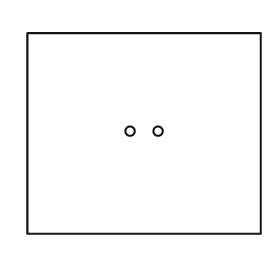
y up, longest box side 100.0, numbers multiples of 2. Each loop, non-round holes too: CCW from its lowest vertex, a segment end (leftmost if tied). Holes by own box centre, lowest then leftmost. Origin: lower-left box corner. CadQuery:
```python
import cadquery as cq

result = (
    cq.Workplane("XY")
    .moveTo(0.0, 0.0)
    .lineTo(100.0, 0.0)
    .lineTo(100.0, 86.0)
    .lineTo(0.0, 86.0)
    .close()
    .moveTo(44.0, 44.0)
    .circle(2.0)
    .moveTo(56.0, 44.0)
    .circle(2.0)
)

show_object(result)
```